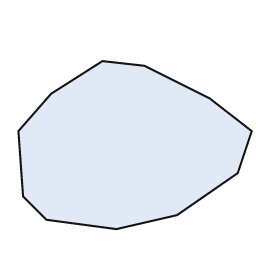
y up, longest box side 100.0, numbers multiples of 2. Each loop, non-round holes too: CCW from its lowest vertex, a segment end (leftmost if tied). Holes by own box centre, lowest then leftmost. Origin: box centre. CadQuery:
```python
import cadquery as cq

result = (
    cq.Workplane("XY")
    .moveTo(-8.0, -36.0)
    .lineTo(18.0, -30.0)
    .lineTo(44.0, -12.0)
    .lineTo(50.0, 6.0)
    .lineTo(32.0, 20.0)
    .lineTo(4.0, 34.0)
    .lineTo(-14.0, 36.0)
    .lineTo(-36.0, 22.0)
    .lineTo(-50.0, 6.0)
    .lineTo(-48.0, -22.0)
    .lineTo(-38.0, -32.0)
    .close()
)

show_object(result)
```